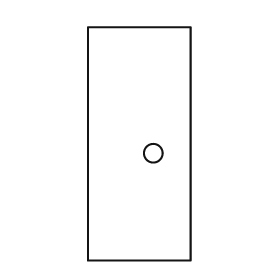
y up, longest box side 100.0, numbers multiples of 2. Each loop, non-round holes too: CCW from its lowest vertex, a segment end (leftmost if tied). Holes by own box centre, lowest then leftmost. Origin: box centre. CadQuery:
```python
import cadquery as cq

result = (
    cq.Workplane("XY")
    .moveTo(-22.0, -50.0)
    .lineTo(22.0, -50.0)
    .lineTo(22.0, 50.0)
    .lineTo(-22.0, 50.0)
    .close()
    .moveTo(6.0, -4.0)
    .circle(4.0)
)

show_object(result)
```